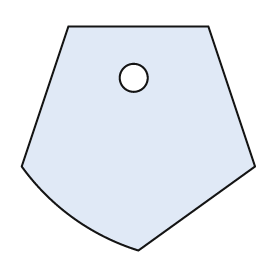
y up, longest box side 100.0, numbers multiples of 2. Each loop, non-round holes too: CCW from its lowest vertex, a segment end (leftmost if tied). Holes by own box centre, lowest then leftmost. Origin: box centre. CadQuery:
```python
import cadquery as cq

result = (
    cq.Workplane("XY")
    .moveTo(0.0, -48.0)
    .lineTo(50.0, -12.0)
    .lineTo(30.0, 48.0)
    .lineTo(-30.0, 48.0)
    .lineTo(-50.0, -12.0)
    .threePointArc((-28.0, -34.0), (0.0, -48.0))
    .close()
    .moveTo(-2.0, 26.0)
    .circle(6.0)
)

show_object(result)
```